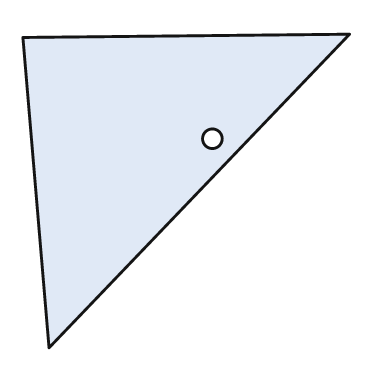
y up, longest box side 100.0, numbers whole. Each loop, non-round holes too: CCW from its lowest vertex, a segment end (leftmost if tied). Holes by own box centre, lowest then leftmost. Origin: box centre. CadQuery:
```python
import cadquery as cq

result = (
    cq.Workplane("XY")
    .moveTo(-42.0, -48.0)
    .lineTo(50.0, 48.0)
    .lineTo(-50.0, 47.0)
    .close()
    .moveTo(8.0, 16.0)
    .circle(3.0)
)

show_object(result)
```